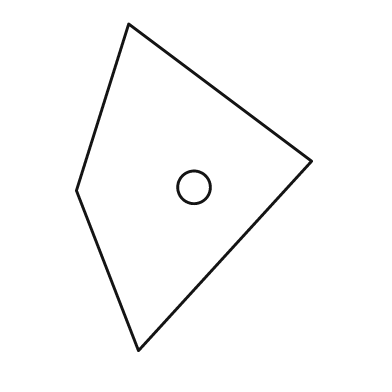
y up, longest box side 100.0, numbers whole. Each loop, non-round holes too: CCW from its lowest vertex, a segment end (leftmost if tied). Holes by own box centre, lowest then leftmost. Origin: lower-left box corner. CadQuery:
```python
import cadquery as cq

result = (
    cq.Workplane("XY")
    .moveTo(19.0, 0.0)
    .lineTo(72.0, 58.0)
    .lineTo(16.0, 100.0)
    .lineTo(0.0, 49.0)
    .close()
    .moveTo(36.0, 50.0)
    .circle(5.0)
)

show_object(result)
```